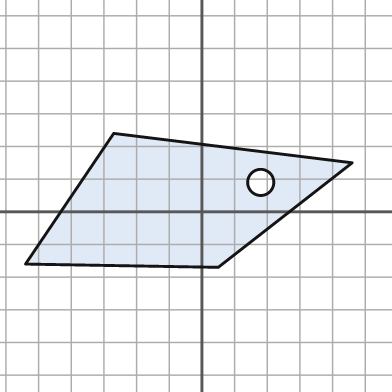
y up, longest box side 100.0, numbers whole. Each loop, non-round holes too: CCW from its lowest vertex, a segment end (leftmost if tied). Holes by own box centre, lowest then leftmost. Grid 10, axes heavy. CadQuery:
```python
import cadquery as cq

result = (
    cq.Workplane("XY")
    .moveTo(5.0, -17.0)
    .lineTo(46.0, 15.0)
    .lineTo(-27.0, 24.0)
    .lineTo(-54.0, -16.0)
    .close()
    .moveTo(18.0, 9.0)
    .circle(4.0)
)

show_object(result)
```